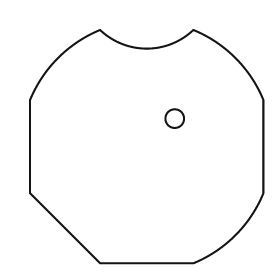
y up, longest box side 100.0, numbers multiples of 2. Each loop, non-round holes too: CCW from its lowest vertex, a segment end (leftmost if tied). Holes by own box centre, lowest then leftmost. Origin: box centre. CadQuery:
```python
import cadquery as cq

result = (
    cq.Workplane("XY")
    .moveTo(-20.0, -50.0)
    .lineTo(20.0, -50.0)
    .threePointArc((38.0, -38.0), (50.0, -20.0))
    .lineTo(50.0, 20.0)
    .threePointArc((38.0, 38.0), (20.0, 50.0))
    .threePointArc((0.0, 42.0), (-20.0, 50.0))
    .threePointArc((-38.0, 38.0), (-50.0, 20.0))
    .lineTo(-50.0, -20.0)
    .close()
    .moveTo(12.0, 12.0)
    .circle(4.0)
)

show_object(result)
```